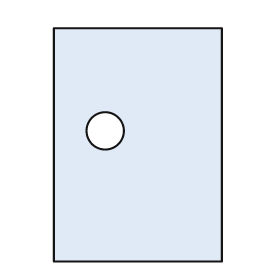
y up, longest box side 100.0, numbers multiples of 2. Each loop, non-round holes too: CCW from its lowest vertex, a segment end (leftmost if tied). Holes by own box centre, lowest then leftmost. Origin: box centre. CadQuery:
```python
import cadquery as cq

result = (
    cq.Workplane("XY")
    .moveTo(-36.0, -50.0)
    .lineTo(36.0, -50.0)
    .lineTo(36.0, 50.0)
    .lineTo(-36.0, 50.0)
    .close()
    .moveTo(-14.0, 6.0)
    .circle(8.0)
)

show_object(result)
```